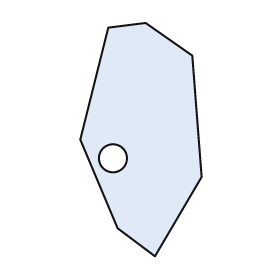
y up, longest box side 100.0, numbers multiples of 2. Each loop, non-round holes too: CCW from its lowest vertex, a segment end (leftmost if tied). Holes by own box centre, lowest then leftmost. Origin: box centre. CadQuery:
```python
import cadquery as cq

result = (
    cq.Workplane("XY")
    .moveTo(6.0, -50.0)
    .lineTo(26.0, -16.0)
    .lineTo(22.0, 36.0)
    .lineTo(2.0, 50.0)
    .lineTo(-14.0, 48.0)
    .lineTo(-26.0, 0.0)
    .lineTo(-10.0, -38.0)
    .close()
    .moveTo(-12.0, -8.0)
    .circle(6.0)
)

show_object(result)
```